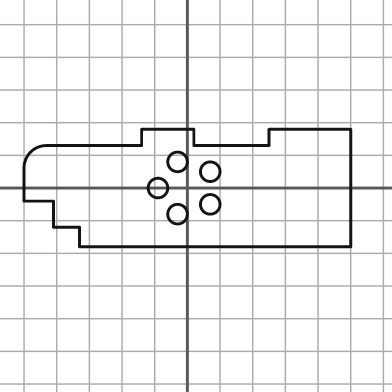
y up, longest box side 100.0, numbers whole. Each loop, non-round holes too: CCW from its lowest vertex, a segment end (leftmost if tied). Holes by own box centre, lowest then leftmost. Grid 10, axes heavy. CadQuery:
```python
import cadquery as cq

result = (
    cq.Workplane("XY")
    .moveTo(-33.0, -18.0)
    .lineTo(50.0, -18.0)
    .lineTo(50.0, 18.0)
    .lineTo(25.0, 18.0)
    .lineTo(25.0, 13.0)
    .lineTo(2.0, 13.0)
    .lineTo(2.0, 18.0)
    .lineTo(-14.0, 18.0)
    .lineTo(-14.0, 13.0)
    .lineTo(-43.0, 13.0)
    .threePointArc((-48.0, 11.0), (-50.0, 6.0))
    .lineTo(-50.0, -4.0)
    .lineTo(-41.0, -4.0)
    .lineTo(-41.0, -12.0)
    .lineTo(-33.0, -12.0)
    .close()
    .moveTo(-3.0, -8.0)
    .circle(3.0)
    .moveTo(7.0, -5.0)
    .circle(3.0)
    .moveTo(-9.0, 0.0)
    .circle(3.0)
    .moveTo(7.0, 5.0)
    .circle(3.0)
    .moveTo(-3.0, 8.0)
    .circle(3.0)
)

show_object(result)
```